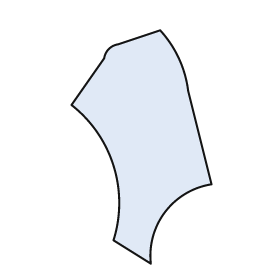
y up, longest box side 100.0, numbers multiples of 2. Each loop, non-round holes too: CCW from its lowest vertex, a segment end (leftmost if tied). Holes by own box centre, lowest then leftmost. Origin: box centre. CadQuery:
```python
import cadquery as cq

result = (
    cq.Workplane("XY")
    .moveTo(4.0, -50.0)
    .threePointArc((10.0, -28.0), (30.0, -16.0))
    .lineTo(20.0, 24.0)
    .threePointArc((16.0, 38.0), (8.0, 50.0))
    .lineTo(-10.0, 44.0)
    .threePointArc((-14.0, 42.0), (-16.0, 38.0))
    .lineTo(-30.0, 18.0)
    .threePointArc((-12.0, -8.0), (-12.0, -40.0))
    .close()
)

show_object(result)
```